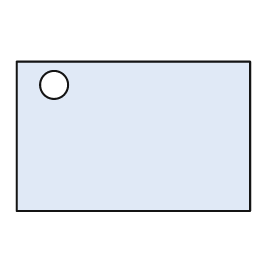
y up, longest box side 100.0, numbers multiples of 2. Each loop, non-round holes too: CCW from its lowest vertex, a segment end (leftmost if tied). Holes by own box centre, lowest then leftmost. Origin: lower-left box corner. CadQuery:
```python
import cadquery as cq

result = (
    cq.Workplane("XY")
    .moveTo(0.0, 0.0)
    .lineTo(100.0, 0.0)
    .lineTo(100.0, 64.0)
    .lineTo(0.0, 64.0)
    .close()
    .moveTo(16.0, 54.0)
    .circle(6.0)
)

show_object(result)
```